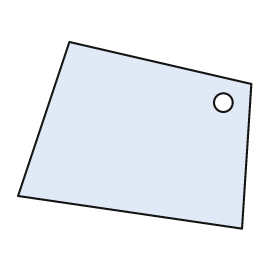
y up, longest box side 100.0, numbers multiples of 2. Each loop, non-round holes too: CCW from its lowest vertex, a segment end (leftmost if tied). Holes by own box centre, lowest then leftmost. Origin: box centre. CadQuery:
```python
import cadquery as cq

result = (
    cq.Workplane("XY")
    .moveTo(46.0, -40.0)
    .lineTo(50.0, 22.0)
    .lineTo(-28.0, 40.0)
    .lineTo(-50.0, -26.0)
    .close()
    .moveTo(38.0, 14.0)
    .circle(4.0)
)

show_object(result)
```